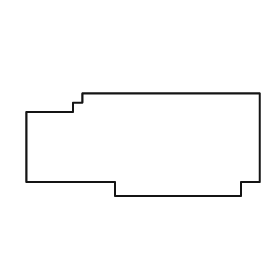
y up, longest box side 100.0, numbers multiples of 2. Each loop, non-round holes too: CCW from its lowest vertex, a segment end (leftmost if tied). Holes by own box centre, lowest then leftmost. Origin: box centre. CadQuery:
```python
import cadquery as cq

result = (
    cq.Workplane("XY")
    .moveTo(-12.0, -22.0)
    .lineTo(42.0, -22.0)
    .lineTo(42.0, -16.0)
    .lineTo(50.0, -16.0)
    .lineTo(50.0, 22.0)
    .lineTo(-26.0, 22.0)
    .lineTo(-26.0, 18.0)
    .lineTo(-30.0, 18.0)
    .lineTo(-30.0, 14.0)
    .lineTo(-50.0, 14.0)
    .lineTo(-50.0, -16.0)
    .lineTo(-12.0, -16.0)
    .close()
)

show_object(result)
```